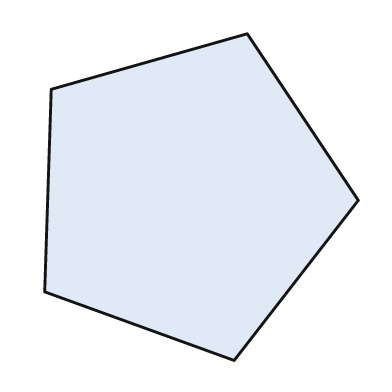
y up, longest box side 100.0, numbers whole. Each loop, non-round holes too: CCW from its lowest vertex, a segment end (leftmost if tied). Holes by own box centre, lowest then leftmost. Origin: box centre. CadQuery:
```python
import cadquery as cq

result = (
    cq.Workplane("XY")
    .moveTo(10.0, -50.0)
    .lineTo(48.0, -1.0)
    .lineTo(14.0, 50.0)
    .lineTo(-46.0, 33.0)
    .lineTo(-48.0, -29.0)
    .close()
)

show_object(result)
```